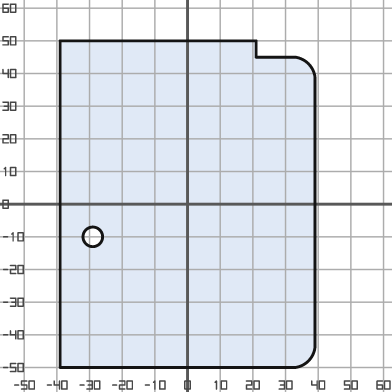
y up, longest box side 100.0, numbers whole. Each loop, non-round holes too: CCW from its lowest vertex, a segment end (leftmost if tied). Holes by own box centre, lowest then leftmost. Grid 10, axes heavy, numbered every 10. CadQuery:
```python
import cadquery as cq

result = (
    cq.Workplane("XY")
    .moveTo(-39.0, -50.0)
    .lineTo(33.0, -50.0)
    .threePointArc((37.0, -48.0), (39.0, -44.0))
    .lineTo(39.0, 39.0)
    .threePointArc((37.0, 43.0), (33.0, 45.0))
    .lineTo(21.0, 45.0)
    .lineTo(21.0, 50.0)
    .lineTo(-39.0, 50.0)
    .close()
    .moveTo(-29.0, -10.0)
    .circle(3.0)
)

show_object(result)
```